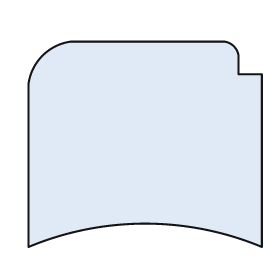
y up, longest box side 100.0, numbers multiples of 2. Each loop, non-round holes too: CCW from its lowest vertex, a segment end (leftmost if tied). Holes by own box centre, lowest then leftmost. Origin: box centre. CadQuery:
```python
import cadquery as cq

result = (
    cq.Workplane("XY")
    .moveTo(-50.0, -44.0)
    .threePointArc((0.0, -34.0), (50.0, -44.0))
    .lineTo(50.0, 30.0)
    .lineTo(40.0, 30.0)
    .lineTo(40.0, 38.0)
    .threePointArc((38.0, 42.0), (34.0, 44.0))
    .lineTo(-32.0, 44.0)
    .threePointArc((-44.0, 38.0), (-50.0, 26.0))
    .close()
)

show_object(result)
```